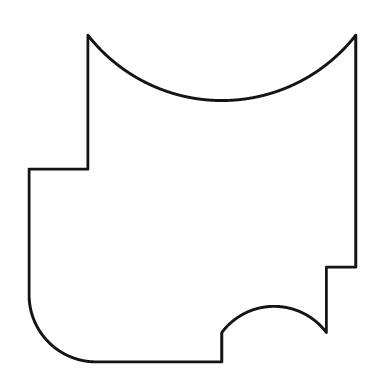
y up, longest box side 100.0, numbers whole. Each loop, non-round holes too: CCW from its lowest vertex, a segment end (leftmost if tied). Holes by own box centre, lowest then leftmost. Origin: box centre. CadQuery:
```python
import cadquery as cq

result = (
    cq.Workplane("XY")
    .moveTo(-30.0, -50.0)
    .lineTo(9.0, -50.0)
    .lineTo(9.0, -41.0)
    .threePointArc((25.0, -33.0), (41.0, -41.0))
    .lineTo(41.0, -21.0)
    .lineTo(50.0, -21.0)
    .lineTo(50.0, 50.0)
    .threePointArc((9.0, 30.0), (-32.0, 50.0))
    .lineTo(-32.0, 9.0)
    .lineTo(-50.0, 9.0)
    .lineTo(-50.0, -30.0)
    .threePointArc((-44.0, -44.0), (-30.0, -50.0))
    .close()
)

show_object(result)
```